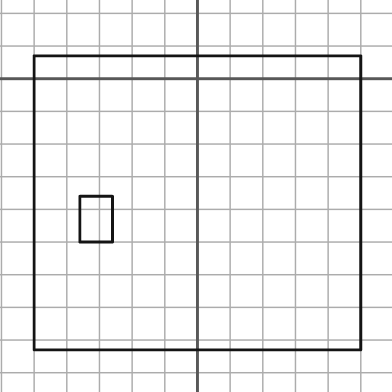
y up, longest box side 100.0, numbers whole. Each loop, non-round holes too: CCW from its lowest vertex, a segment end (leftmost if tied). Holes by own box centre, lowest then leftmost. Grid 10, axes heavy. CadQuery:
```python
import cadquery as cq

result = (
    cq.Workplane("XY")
    .moveTo(-50.0, -83.0)
    .lineTo(50.0, -83.0)
    .lineTo(50.0, 7.0)
    .lineTo(-50.0, 7.0)
    .close()
    .moveTo(-36.0, -50.0)
    .lineTo(-26.0, -50.0)
    .lineTo(-26.0, -36.0)
    .lineTo(-36.0, -36.0)
    .close()
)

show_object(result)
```